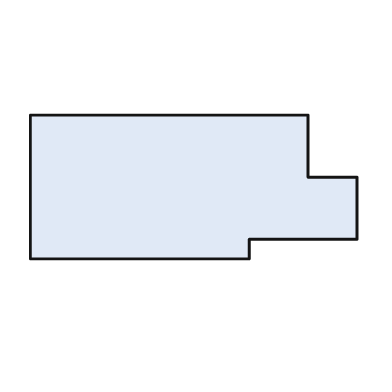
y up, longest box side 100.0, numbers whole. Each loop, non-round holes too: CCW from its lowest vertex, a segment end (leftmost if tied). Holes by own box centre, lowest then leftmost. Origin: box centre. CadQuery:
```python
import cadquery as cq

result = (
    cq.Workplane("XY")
    .moveTo(-50.0, -22.0)
    .lineTo(17.0, -22.0)
    .lineTo(17.0, -16.0)
    .lineTo(50.0, -16.0)
    .lineTo(50.0, 3.0)
    .lineTo(35.0, 3.0)
    .lineTo(35.0, 22.0)
    .lineTo(-50.0, 22.0)
    .close()
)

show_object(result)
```